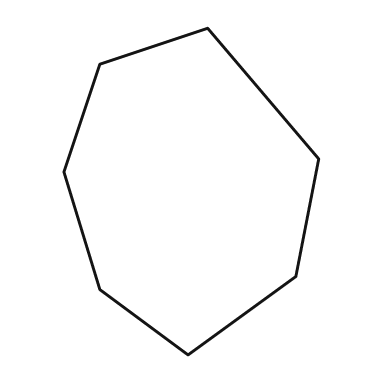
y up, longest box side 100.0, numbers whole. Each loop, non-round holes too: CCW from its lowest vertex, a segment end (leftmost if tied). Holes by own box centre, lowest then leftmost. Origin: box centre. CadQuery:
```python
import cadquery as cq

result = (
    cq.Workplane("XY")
    .moveTo(-1.0, -50.0)
    .lineTo(32.0, -26.0)
    .lineTo(39.0, 10.0)
    .lineTo(5.0, 50.0)
    .lineTo(-28.0, 39.0)
    .lineTo(-39.0, 6.0)
    .lineTo(-28.0, -30.0)
    .close()
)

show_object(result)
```